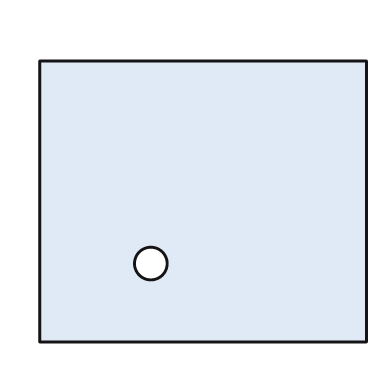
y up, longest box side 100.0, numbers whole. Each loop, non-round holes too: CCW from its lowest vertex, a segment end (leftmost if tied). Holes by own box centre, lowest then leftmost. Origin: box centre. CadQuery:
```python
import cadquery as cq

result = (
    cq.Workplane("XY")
    .moveTo(-50.0, -43.0)
    .lineTo(50.0, -43.0)
    .lineTo(50.0, 43.0)
    .lineTo(-50.0, 43.0)
    .close()
    .moveTo(-16.0, -19.0)
    .circle(5.0)
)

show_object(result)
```